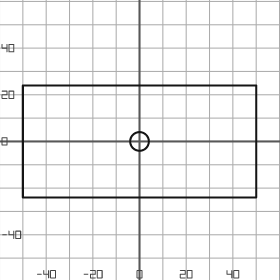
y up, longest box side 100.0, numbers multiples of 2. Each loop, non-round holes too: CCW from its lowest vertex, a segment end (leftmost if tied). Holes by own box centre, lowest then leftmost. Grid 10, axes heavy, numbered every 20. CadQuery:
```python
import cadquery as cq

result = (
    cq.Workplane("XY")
    .moveTo(-50.0, -24.0)
    .lineTo(50.0, -24.0)
    .lineTo(50.0, 24.0)
    .lineTo(-50.0, 24.0)
    .close()
    .moveTo(0.0, 0.0)
    .circle(4.0)
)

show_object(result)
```